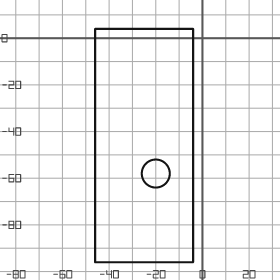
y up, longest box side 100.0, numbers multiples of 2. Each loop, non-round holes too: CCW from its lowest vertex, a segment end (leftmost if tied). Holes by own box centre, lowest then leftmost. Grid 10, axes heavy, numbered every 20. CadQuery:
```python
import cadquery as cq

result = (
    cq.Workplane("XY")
    .moveTo(-46.0, -96.0)
    .lineTo(-4.0, -96.0)
    .lineTo(-4.0, 4.0)
    .lineTo(-46.0, 4.0)
    .close()
    .moveTo(-20.0, -58.0)
    .circle(6.0)
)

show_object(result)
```